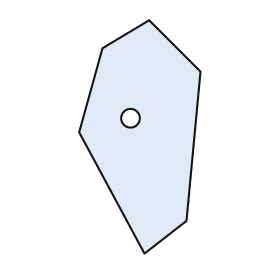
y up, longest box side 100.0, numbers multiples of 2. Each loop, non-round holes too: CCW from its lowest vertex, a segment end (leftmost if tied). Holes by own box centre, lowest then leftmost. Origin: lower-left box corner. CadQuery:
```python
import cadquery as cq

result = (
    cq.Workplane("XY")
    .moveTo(28.0, 0.0)
    .lineTo(46.0, 14.0)
    .lineTo(52.0, 78.0)
    .lineTo(30.0, 100.0)
    .lineTo(10.0, 88.0)
    .lineTo(0.0, 52.0)
    .close()
    .moveTo(22.0, 58.0)
    .circle(4.0)
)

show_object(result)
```